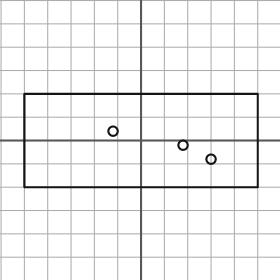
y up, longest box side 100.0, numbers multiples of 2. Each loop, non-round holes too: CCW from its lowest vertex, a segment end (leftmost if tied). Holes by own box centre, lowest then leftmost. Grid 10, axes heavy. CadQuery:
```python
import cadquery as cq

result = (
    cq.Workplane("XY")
    .moveTo(-50.0, -20.0)
    .lineTo(50.0, -20.0)
    .lineTo(50.0, 20.0)
    .lineTo(-50.0, 20.0)
    .close()
    .moveTo(30.0, -8.0)
    .circle(2.0)
    .moveTo(18.0, -2.0)
    .circle(2.0)
    .moveTo(-12.0, 4.0)
    .circle(2.0)
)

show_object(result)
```